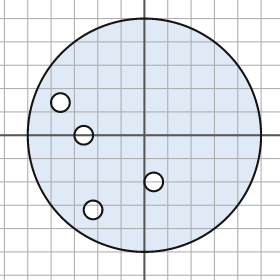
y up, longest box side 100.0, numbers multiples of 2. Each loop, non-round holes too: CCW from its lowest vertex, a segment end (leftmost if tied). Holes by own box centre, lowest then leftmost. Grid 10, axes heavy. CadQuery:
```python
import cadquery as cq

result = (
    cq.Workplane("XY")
    .moveTo(0.0, 0.0)
    .circle(50.0)
    .moveTo(-22.0, -32.0)
    .circle(4.0)
    .moveTo(4.0, -20.0)
    .circle(4.0)
    .moveTo(-26.0, 0.0)
    .circle(4.0)
    .moveTo(-36.0, 14.0)
    .circle(4.0)
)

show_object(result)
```